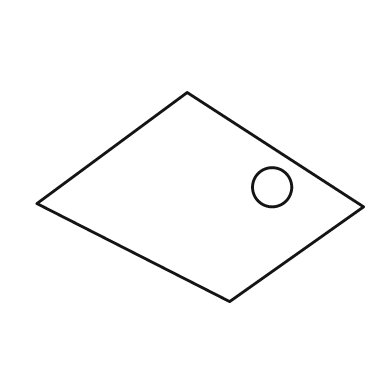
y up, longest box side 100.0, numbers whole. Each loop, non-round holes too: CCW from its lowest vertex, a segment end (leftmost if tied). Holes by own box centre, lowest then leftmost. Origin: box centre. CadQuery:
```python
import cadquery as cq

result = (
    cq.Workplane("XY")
    .moveTo(9.0, -32.0)
    .lineTo(50.0, -3.0)
    .lineTo(-4.0, 32.0)
    .lineTo(-50.0, -2.0)
    .close()
    .moveTo(22.0, 3.0)
    .circle(6.0)
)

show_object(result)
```